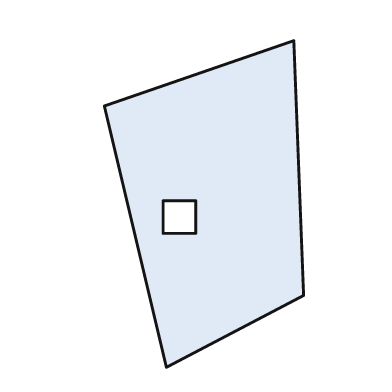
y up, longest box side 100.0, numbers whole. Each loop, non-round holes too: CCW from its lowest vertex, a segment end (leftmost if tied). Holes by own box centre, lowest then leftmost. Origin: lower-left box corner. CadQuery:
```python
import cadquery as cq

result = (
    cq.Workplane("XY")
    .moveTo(19.0, 0.0)
    .lineTo(61.0, 22.0)
    .lineTo(58.0, 100.0)
    .lineTo(0.0, 80.0)
    .close()
    .moveTo(18.0, 41.0)
    .lineTo(28.0, 41.0)
    .lineTo(28.0, 51.0)
    .lineTo(18.0, 51.0)
    .close()
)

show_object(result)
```